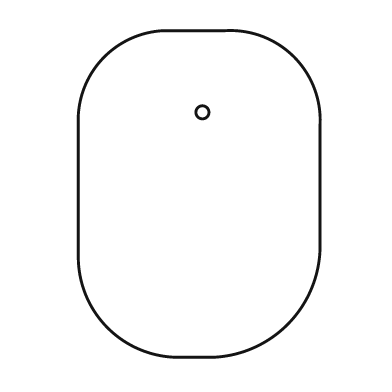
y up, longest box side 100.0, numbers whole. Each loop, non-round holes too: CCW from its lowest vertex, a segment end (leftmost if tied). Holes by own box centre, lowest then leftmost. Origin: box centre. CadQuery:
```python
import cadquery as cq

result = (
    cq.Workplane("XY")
    .moveTo(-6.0, -50.0)
    .lineTo(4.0, -50.0)
    .threePointArc((27.0, -40.0), (37.0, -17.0))
    .lineTo(37.0, 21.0)
    .threePointArc((29.0, 42.0), (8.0, 50.0))
    .lineTo(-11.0, 50.0)
    .threePointArc((-29.0, 42.0), (-37.0, 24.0))
    .lineTo(-37.0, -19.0)
    .threePointArc((-28.0, -41.0), (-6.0, -50.0))
    .close()
    .moveTo(1.0, 25.0)
    .circle(2.0)
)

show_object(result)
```